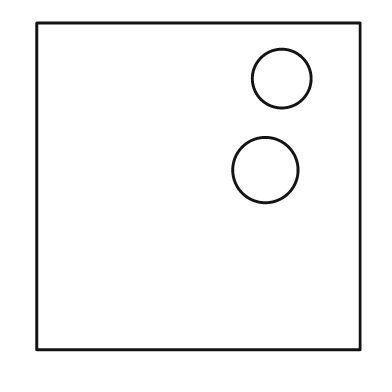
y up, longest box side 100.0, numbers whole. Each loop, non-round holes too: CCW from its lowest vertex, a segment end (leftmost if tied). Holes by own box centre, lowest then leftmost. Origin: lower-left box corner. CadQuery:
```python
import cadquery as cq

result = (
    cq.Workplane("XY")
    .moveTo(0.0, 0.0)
    .lineTo(99.0, 0.0)
    .lineTo(99.0, 100.0)
    .lineTo(0.0, 100.0)
    .close()
    .moveTo(70.0, 55.0)
    .circle(10.0)
    .moveTo(75.0, 83.0)
    .circle(9.0)
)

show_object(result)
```